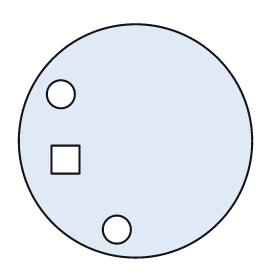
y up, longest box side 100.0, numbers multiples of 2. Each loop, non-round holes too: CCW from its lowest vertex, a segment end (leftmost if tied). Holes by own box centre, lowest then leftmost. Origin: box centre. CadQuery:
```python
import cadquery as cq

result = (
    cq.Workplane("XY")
    .moveTo(0.0, 0.0)
    .circle(50.0)
    .moveTo(-8.0, -38.0)
    .circle(6.0)
    .moveTo(-36.0, -14.0)
    .lineTo(-24.0, -14.0)
    .lineTo(-24.0, -2.0)
    .lineTo(-36.0, -2.0)
    .close()
    .moveTo(-32.0, 20.0)
    .circle(6.0)
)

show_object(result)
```